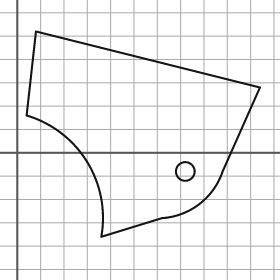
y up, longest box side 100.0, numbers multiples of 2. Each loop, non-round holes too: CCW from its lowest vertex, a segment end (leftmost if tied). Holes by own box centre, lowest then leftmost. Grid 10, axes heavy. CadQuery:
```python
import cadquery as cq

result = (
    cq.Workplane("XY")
    .moveTo(36.0, -36.0)
    .lineTo(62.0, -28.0)
    .threePointArc((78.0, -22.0), (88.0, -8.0))
    .lineTo(104.0, 28.0)
    .lineTo(8.0, 52.0)
    .lineTo(4.0, 16.0)
    .threePointArc((30.0, -4.0), (36.0, -36.0))
    .close()
    .moveTo(72.0, -8.0)
    .circle(4.0)
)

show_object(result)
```